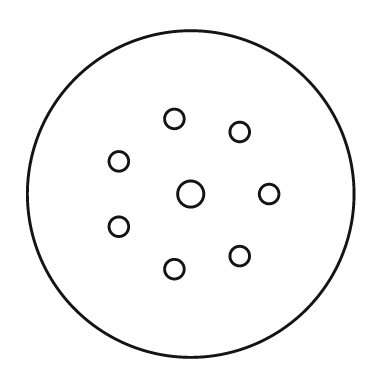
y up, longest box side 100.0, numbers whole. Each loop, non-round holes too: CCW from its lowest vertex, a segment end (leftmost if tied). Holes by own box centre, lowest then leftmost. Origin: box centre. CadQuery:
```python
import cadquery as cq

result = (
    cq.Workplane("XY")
    .moveTo(0.0, 0.0)
    .circle(50.0)
    .moveTo(-5.0, -23.0)
    .circle(3.0)
    .moveTo(15.0, -19.0)
    .circle(3.0)
    .moveTo(-22.0, -10.0)
    .circle(3.0)
    .moveTo(0.0, 0.0)
    .circle(4.0)
    .moveTo(24.0, 0.0)
    .circle(3.0)
    .moveTo(-22.0, 10.0)
    .circle(3.0)
    .moveTo(15.0, 19.0)
    .circle(3.0)
    .moveTo(-5.0, 23.0)
    .circle(3.0)
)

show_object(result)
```